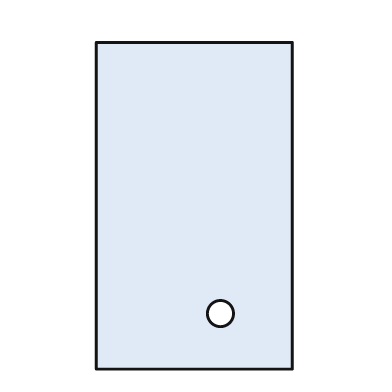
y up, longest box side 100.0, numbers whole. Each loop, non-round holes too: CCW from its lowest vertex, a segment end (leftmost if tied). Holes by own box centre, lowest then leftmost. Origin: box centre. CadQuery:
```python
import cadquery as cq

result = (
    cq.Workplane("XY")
    .moveTo(-30.0, -50.0)
    .lineTo(30.0, -50.0)
    .lineTo(30.0, 50.0)
    .lineTo(-30.0, 50.0)
    .close()
    .moveTo(8.0, -33.0)
    .circle(4.0)
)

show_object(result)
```